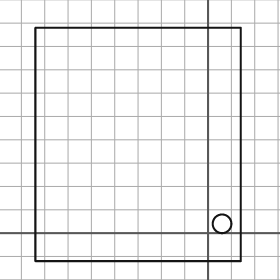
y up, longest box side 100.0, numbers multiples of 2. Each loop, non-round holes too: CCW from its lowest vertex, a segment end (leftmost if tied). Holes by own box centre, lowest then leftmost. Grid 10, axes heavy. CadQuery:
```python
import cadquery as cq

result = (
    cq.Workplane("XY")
    .moveTo(-74.0, -12.0)
    .lineTo(14.0, -12.0)
    .lineTo(14.0, 88.0)
    .lineTo(-74.0, 88.0)
    .close()
    .moveTo(6.0, 4.0)
    .circle(4.0)
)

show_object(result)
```